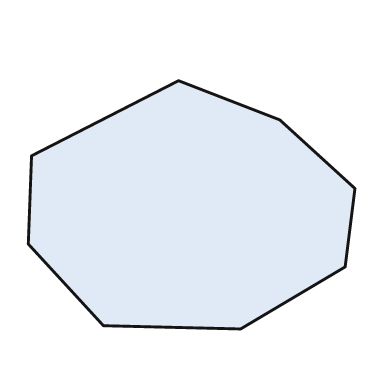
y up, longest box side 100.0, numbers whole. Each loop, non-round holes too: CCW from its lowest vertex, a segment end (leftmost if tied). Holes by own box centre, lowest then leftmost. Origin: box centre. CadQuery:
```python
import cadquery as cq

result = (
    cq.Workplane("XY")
    .moveTo(15.0, -38.0)
    .lineTo(47.0, -19.0)
    .lineTo(50.0, 5.0)
    .lineTo(27.0, 26.0)
    .lineTo(-4.0, 38.0)
    .lineTo(-49.0, 15.0)
    .lineTo(-50.0, -12.0)
    .lineTo(-27.0, -37.0)
    .close()
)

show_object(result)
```